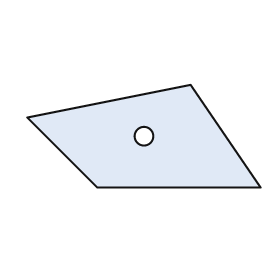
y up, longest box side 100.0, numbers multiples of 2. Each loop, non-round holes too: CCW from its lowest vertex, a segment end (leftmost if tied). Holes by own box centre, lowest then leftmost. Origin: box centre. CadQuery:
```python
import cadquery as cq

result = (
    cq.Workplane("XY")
    .moveTo(-20.0, -22.0)
    .lineTo(50.0, -22.0)
    .lineTo(20.0, 22.0)
    .lineTo(-50.0, 8.0)
    .close()
    .moveTo(0.0, 0.0)
    .circle(4.0)
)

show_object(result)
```